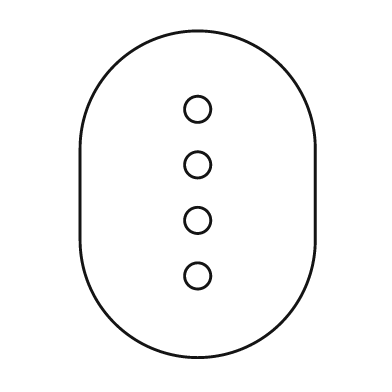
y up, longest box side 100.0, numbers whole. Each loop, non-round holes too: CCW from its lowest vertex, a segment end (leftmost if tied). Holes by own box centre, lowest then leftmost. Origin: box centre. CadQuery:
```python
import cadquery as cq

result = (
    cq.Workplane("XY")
    .moveTo(-36.0, -14.0)
    .threePointArc((0.0, -50.0), (36.0, -14.0))
    .lineTo(36.0, 14.0)
    .threePointArc((0.0, 50.0), (-36.0, 14.0))
    .close()
    .moveTo(0.0, -25.0)
    .circle(4.0)
    .moveTo(0.0, -8.0)
    .circle(4.0)
    .moveTo(0.0, 9.0)
    .circle(4.0)
    .moveTo(0.0, 26.0)
    .circle(4.0)
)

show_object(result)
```